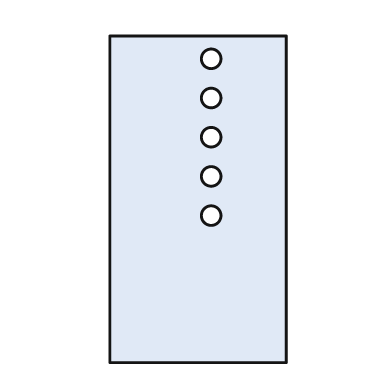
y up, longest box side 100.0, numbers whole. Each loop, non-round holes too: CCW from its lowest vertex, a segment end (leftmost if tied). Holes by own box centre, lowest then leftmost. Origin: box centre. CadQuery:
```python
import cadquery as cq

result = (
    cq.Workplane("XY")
    .moveTo(-27.0, -50.0)
    .lineTo(27.0, -50.0)
    .lineTo(27.0, 50.0)
    .lineTo(-27.0, 50.0)
    .close()
    .moveTo(4.0, -5.0)
    .circle(3.0)
    .moveTo(4.0, 7.0)
    .circle(3.0)
    .moveTo(4.0, 19.0)
    .circle(3.0)
    .moveTo(4.0, 31.0)
    .circle(3.0)
    .moveTo(4.0, 43.0)
    .circle(3.0)
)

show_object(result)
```